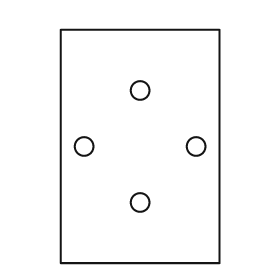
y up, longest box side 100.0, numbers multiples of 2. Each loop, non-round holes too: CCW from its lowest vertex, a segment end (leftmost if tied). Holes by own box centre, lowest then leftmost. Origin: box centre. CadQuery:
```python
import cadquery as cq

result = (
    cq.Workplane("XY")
    .moveTo(-34.0, -50.0)
    .lineTo(34.0, -50.0)
    .lineTo(34.0, 50.0)
    .lineTo(-34.0, 50.0)
    .close()
    .moveTo(0.0, -24.0)
    .circle(4.0)
    .moveTo(-24.0, 0.0)
    .circle(4.0)
    .moveTo(24.0, 0.0)
    .circle(4.0)
    .moveTo(0.0, 24.0)
    .circle(4.0)
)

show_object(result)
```